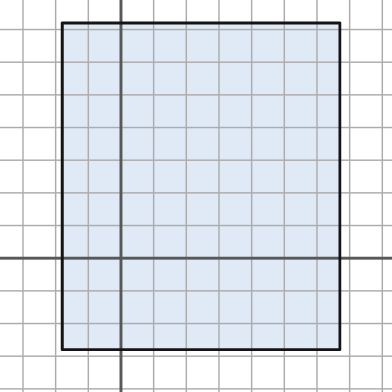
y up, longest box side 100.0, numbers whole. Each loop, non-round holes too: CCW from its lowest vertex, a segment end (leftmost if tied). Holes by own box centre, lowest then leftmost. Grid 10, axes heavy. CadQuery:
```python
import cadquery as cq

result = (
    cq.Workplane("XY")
    .moveTo(-18.0, -28.0)
    .lineTo(67.0, -28.0)
    .lineTo(67.0, 72.0)
    .lineTo(-18.0, 72.0)
    .close()
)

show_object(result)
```